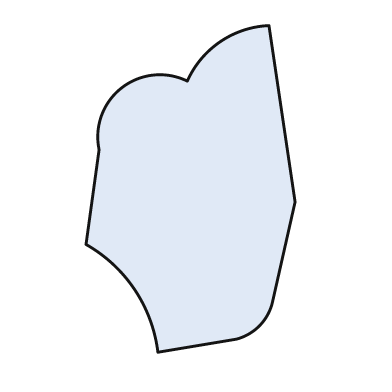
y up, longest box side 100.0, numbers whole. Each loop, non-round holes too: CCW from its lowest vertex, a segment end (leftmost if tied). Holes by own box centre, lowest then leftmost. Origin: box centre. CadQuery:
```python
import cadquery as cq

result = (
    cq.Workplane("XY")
    .moveTo(-10.0, -50.0)
    .lineTo(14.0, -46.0)
    .threePointArc((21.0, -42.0), (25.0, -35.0))
    .lineTo(32.0, -4.0)
    .lineTo(24.0, 50.0)
    .threePointArc((9.0, 45.0), (-1.0, 33.0))
    .threePointArc((-21.0, 31.0), (-28.0, 12.0))
    .lineTo(-32.0, -17.0)
    .threePointArc((-17.0, -31.0), (-10.0, -50.0))
    .close()
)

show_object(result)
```